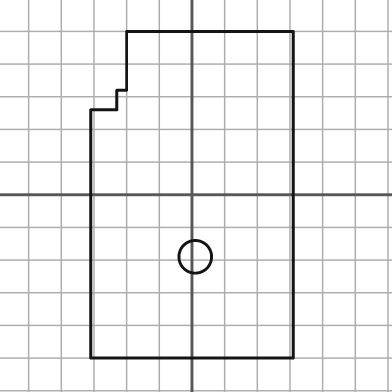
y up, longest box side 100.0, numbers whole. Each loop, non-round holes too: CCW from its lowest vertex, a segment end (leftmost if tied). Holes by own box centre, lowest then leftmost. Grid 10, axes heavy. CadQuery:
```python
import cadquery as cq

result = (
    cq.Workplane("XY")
    .moveTo(-31.0, -50.0)
    .lineTo(31.0, -50.0)
    .lineTo(31.0, 50.0)
    .lineTo(-20.0, 50.0)
    .lineTo(-20.0, 32.0)
    .lineTo(-23.0, 32.0)
    .lineTo(-23.0, 26.0)
    .lineTo(-31.0, 26.0)
    .close()
    .moveTo(1.0, -19.0)
    .circle(5.0)
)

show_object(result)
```